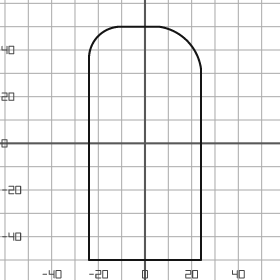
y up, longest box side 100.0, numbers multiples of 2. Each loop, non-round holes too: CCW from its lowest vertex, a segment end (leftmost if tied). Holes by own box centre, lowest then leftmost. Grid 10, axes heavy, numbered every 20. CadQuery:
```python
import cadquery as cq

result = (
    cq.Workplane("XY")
    .moveTo(-24.0, -50.0)
    .lineTo(24.0, -50.0)
    .lineTo(24.0, 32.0)
    .threePointArc((18.0, 44.0), (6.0, 50.0))
    .lineTo(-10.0, 50.0)
    .threePointArc((-20.0, 46.0), (-24.0, 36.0))
    .close()
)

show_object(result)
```